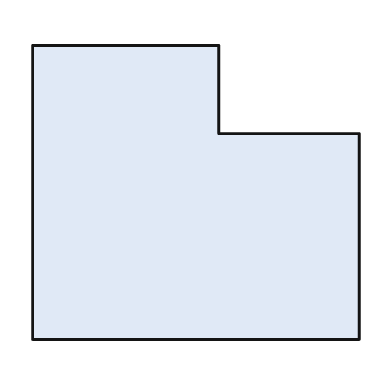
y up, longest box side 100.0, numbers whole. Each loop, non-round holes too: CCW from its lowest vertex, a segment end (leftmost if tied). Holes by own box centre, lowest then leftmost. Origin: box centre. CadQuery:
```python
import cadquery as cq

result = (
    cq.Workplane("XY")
    .moveTo(-50.0, -45.0)
    .lineTo(50.0, -45.0)
    .lineTo(50.0, 18.0)
    .lineTo(7.0, 18.0)
    .lineTo(7.0, 45.0)
    .lineTo(-50.0, 45.0)
    .close()
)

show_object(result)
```